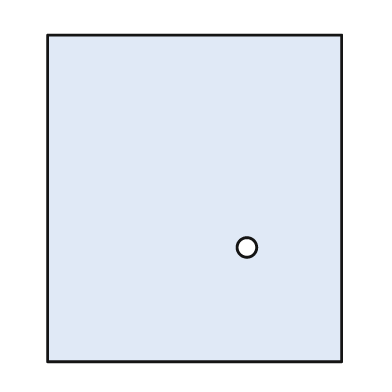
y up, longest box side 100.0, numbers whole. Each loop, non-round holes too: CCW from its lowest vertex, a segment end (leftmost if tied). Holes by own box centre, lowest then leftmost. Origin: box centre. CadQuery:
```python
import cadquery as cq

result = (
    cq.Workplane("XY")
    .moveTo(-45.0, -50.0)
    .lineTo(45.0, -50.0)
    .lineTo(45.0, 50.0)
    .lineTo(-45.0, 50.0)
    .close()
    .moveTo(16.0, -15.0)
    .circle(3.0)
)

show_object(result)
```